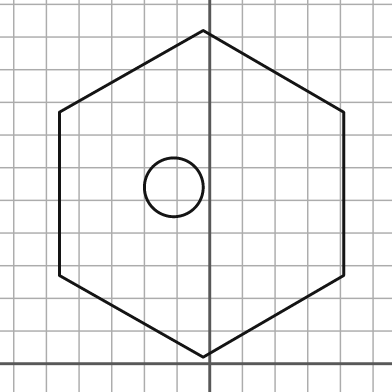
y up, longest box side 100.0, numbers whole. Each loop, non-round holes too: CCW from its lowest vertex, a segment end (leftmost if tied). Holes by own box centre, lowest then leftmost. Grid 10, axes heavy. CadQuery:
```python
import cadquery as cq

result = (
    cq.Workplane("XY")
    .moveTo(-2.0, 2.0)
    .lineTo(41.0, 27.0)
    .lineTo(41.0, 77.0)
    .lineTo(-2.0, 102.0)
    .lineTo(-46.0, 77.0)
    .lineTo(-46.0, 27.0)
    .close()
    .moveTo(-11.0, 54.0)
    .circle(9.0)
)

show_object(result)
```